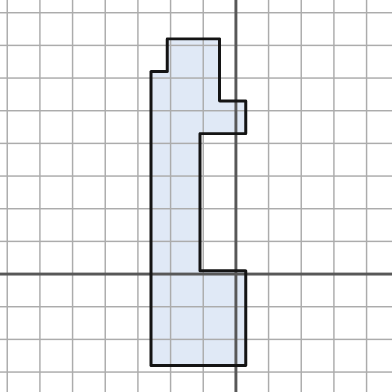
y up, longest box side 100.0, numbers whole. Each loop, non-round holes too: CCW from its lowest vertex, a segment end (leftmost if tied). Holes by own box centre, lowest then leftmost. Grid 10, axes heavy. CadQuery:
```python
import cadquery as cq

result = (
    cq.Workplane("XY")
    .moveTo(-26.0, -28.0)
    .lineTo(3.0, -28.0)
    .lineTo(3.0, 1.0)
    .lineTo(-11.0, 1.0)
    .lineTo(-11.0, 43.0)
    .lineTo(3.0, 43.0)
    .lineTo(3.0, 53.0)
    .lineTo(-5.0, 53.0)
    .lineTo(-5.0, 72.0)
    .lineTo(-21.0, 72.0)
    .lineTo(-21.0, 62.0)
    .lineTo(-26.0, 62.0)
    .close()
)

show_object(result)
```